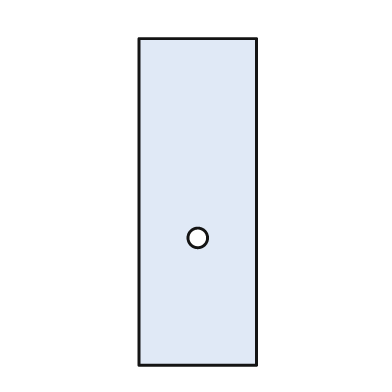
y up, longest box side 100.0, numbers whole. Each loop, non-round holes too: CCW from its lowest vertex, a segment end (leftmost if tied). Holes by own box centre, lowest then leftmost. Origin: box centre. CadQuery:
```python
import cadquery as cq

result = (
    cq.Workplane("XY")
    .moveTo(-18.0, -50.0)
    .lineTo(18.0, -50.0)
    .lineTo(18.0, 50.0)
    .lineTo(-18.0, 50.0)
    .close()
    .moveTo(0.0, -11.0)
    .circle(3.0)
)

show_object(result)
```